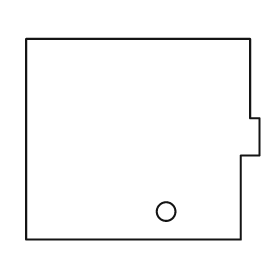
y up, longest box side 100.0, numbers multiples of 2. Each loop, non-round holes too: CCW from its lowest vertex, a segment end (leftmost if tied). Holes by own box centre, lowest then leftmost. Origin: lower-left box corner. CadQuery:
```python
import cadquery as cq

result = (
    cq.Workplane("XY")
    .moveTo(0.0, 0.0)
    .lineTo(92.0, 0.0)
    .lineTo(92.0, 36.0)
    .lineTo(100.0, 36.0)
    .lineTo(100.0, 52.0)
    .lineTo(96.0, 52.0)
    .lineTo(96.0, 86.0)
    .lineTo(0.0, 86.0)
    .close()
    .moveTo(60.0, 12.0)
    .circle(4.0)
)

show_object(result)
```